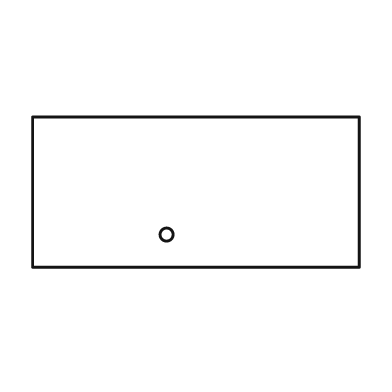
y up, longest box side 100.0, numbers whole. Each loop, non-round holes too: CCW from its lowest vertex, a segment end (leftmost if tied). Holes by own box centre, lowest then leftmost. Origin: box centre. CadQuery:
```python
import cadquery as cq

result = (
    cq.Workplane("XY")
    .moveTo(-50.0, -23.0)
    .lineTo(50.0, -23.0)
    .lineTo(50.0, 23.0)
    .lineTo(-50.0, 23.0)
    .close()
    .moveTo(-9.0, -13.0)
    .circle(2.0)
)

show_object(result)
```